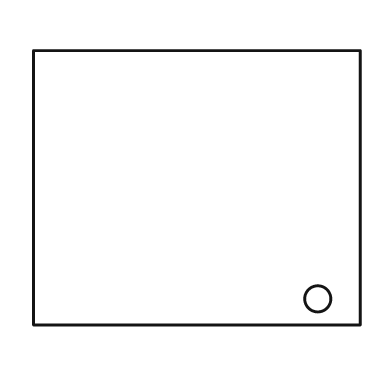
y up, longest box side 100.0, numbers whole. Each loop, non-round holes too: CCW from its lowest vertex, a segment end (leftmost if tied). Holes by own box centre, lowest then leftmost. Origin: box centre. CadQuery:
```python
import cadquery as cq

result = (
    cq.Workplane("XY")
    .moveTo(-50.0, -42.0)
    .lineTo(50.0, -42.0)
    .lineTo(50.0, 42.0)
    .lineTo(-50.0, 42.0)
    .close()
    .moveTo(37.0, -34.0)
    .circle(4.0)
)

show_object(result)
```